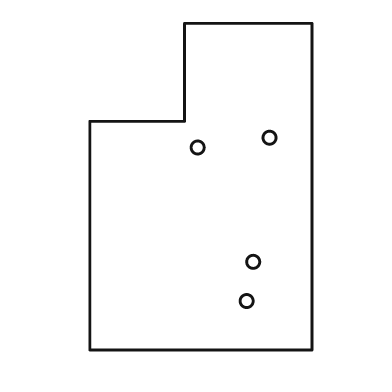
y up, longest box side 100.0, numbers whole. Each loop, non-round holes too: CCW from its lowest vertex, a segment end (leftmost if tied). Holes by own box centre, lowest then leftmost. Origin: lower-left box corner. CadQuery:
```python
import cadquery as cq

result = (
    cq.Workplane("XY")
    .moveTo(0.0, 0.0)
    .lineTo(68.0, 0.0)
    .lineTo(68.0, 100.0)
    .lineTo(29.0, 100.0)
    .lineTo(29.0, 70.0)
    .lineTo(0.0, 70.0)
    .close()
    .moveTo(48.0, 15.0)
    .circle(2.0)
    .moveTo(50.0, 27.0)
    .circle(2.0)
    .moveTo(33.0, 62.0)
    .circle(2.0)
    .moveTo(55.0, 65.0)
    .circle(2.0)
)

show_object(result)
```